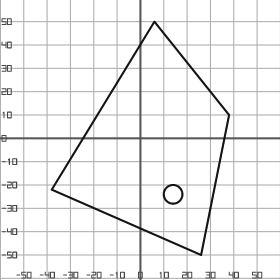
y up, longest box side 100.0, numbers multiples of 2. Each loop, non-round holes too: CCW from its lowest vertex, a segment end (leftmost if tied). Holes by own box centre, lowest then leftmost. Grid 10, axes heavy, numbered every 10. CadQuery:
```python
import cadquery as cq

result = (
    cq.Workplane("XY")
    .moveTo(26.0, -50.0)
    .lineTo(38.0, 10.0)
    .lineTo(6.0, 50.0)
    .lineTo(-38.0, -22.0)
    .close()
    .moveTo(14.0, -24.0)
    .circle(4.0)
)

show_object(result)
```